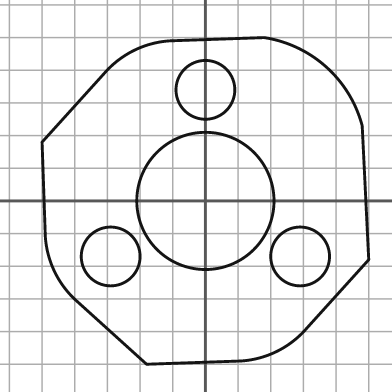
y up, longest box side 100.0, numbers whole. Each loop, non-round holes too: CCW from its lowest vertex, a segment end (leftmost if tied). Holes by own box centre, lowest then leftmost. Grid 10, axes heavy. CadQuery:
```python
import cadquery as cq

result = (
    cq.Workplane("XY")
    .moveTo(-18.0, -50.0)
    .lineTo(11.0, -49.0)
    .threePointArc((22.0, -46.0), (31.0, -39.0))
    .lineTo(50.0, -18.0)
    .lineTo(48.0, 23.0)
    .threePointArc((37.0, 41.0), (18.0, 50.0))
    .lineTo(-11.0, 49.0)
    .threePointArc((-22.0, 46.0), (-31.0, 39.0))
    .lineTo(-50.0, 18.0)
    .lineTo(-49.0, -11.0)
    .threePointArc((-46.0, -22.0), (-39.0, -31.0))
    .close()
    .moveTo(-29.0, -17.0)
    .circle(9.0)
    .moveTo(29.0, -17.0)
    .circle(9.0)
    .moveTo(0.0, 0.0)
    .circle(21.0)
    .moveTo(0.0, 34.0)
    .circle(9.0)
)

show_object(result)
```